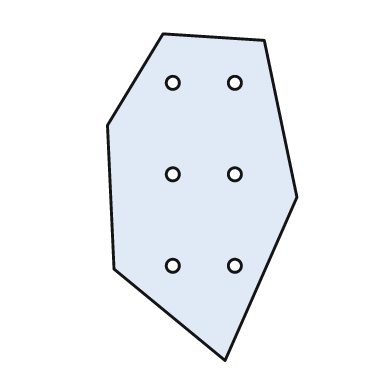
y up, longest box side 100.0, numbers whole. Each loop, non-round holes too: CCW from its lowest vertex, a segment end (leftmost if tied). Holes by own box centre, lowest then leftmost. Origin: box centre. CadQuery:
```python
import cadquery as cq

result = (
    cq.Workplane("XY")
    .moveTo(7.0, -50.0)
    .lineTo(29.0, 0.0)
    .lineTo(19.0, 48.0)
    .lineTo(-12.0, 50.0)
    .lineTo(-29.0, 22.0)
    .lineTo(-27.0, -22.0)
    .close()
    .moveTo(-9.0, -21.0)
    .circle(2.0)
    .moveTo(10.0, -21.0)
    .circle(2.0)
    .moveTo(-9.0, 7.0)
    .circle(2.0)
    .moveTo(10.0, 7.0)
    .circle(2.0)
    .moveTo(-9.0, 35.0)
    .circle(2.0)
    .moveTo(10.0, 35.0)
    .circle(2.0)
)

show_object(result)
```